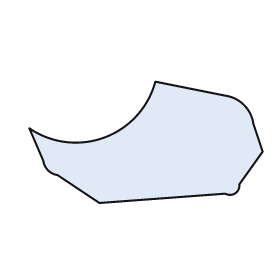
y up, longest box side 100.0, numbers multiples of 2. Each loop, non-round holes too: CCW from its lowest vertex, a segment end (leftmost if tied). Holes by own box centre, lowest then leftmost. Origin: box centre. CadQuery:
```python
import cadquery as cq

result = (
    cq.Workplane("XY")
    .moveTo(-20.0, -26.0)
    .lineTo(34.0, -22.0)
    .threePointArc((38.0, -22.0), (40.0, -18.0))
    .lineTo(50.0, -4.0)
    .lineTo(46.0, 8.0)
    .threePointArc((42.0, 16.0), (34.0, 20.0))
    .lineTo(4.0, 26.0)
    .threePointArc((-18.0, 2.0), (-50.0, 6.0))
    .lineTo(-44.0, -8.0)
    .threePointArc((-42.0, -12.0), (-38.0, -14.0))
    .close()
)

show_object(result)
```